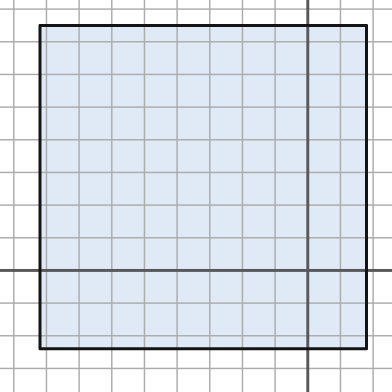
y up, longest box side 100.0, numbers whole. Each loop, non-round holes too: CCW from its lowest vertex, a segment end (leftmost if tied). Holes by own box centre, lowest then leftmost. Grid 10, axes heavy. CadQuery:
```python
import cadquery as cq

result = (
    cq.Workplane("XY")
    .moveTo(-82.0, -24.0)
    .lineTo(18.0, -24.0)
    .lineTo(18.0, 75.0)
    .lineTo(-82.0, 75.0)
    .close()
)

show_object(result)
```